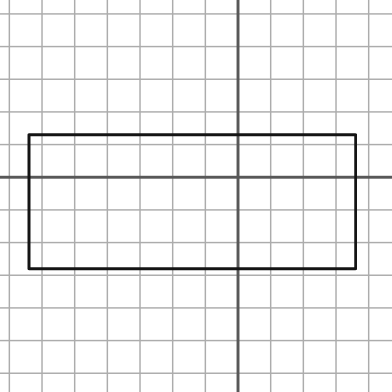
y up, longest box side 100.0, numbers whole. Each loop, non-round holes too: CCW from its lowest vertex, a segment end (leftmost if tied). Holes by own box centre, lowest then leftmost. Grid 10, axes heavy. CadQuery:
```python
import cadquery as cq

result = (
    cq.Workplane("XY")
    .moveTo(-64.0, -28.0)
    .lineTo(36.0, -28.0)
    .lineTo(36.0, 13.0)
    .lineTo(-64.0, 13.0)
    .close()
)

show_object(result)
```